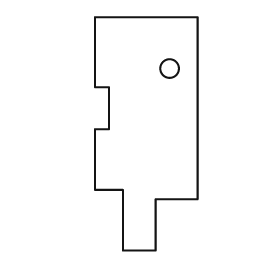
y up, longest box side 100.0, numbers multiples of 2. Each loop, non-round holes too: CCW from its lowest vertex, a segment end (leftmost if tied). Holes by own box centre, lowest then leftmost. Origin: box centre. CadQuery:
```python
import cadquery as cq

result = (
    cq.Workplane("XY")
    .moveTo(-10.0, -50.0)
    .lineTo(4.0, -50.0)
    .lineTo(4.0, -28.0)
    .lineTo(22.0, -28.0)
    .lineTo(22.0, 50.0)
    .lineTo(-22.0, 50.0)
    .lineTo(-22.0, 20.0)
    .lineTo(-16.0, 20.0)
    .lineTo(-16.0, 2.0)
    .lineTo(-22.0, 2.0)
    .lineTo(-22.0, -24.0)
    .lineTo(-10.0, -24.0)
    .close()
    .moveTo(10.0, 28.0)
    .circle(4.0)
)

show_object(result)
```